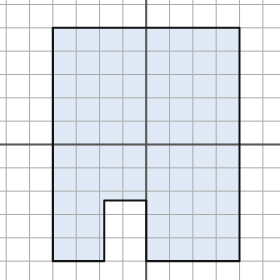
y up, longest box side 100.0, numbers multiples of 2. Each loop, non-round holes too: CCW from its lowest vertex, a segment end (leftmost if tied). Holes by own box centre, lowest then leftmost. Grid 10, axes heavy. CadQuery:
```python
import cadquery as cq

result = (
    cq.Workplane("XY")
    .moveTo(-40.0, -50.0)
    .lineTo(-18.0, -50.0)
    .lineTo(-18.0, -24.0)
    .lineTo(0.0, -24.0)
    .lineTo(0.0, -50.0)
    .lineTo(40.0, -50.0)
    .lineTo(40.0, 50.0)
    .lineTo(-40.0, 50.0)
    .close()
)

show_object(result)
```